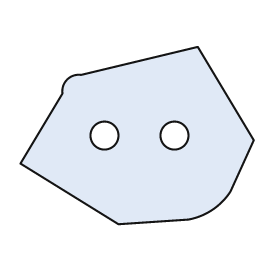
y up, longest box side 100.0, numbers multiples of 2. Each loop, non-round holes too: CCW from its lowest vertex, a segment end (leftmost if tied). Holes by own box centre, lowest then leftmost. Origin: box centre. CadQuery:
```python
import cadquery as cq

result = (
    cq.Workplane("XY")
    .moveTo(-8.0, -38.0)
    .lineTo(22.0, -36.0)
    .threePointArc((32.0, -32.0), (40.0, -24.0))
    .lineTo(50.0, -2.0)
    .lineTo(26.0, 38.0)
    .lineTo(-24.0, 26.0)
    .threePointArc((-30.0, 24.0), (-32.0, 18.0))
    .lineTo(-50.0, -12.0)
    .close()
    .moveTo(-14.0, 0.0)
    .circle(6.0)
    .moveTo(16.0, 0.0)
    .circle(6.0)
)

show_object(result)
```